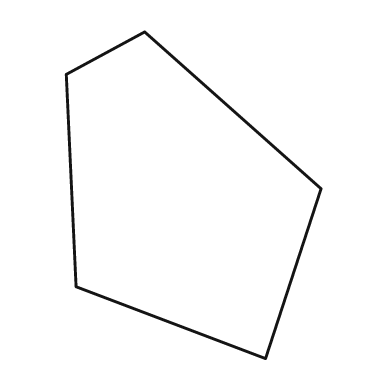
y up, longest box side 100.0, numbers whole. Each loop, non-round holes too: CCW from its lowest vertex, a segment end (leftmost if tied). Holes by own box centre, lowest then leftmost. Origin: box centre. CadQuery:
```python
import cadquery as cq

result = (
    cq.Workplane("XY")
    .moveTo(22.0, -50.0)
    .lineTo(39.0, 2.0)
    .lineTo(-15.0, 50.0)
    .lineTo(-39.0, 37.0)
    .lineTo(-36.0, -28.0)
    .close()
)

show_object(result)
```